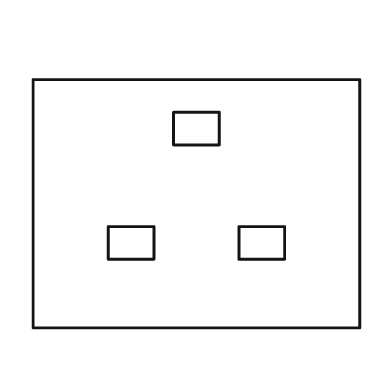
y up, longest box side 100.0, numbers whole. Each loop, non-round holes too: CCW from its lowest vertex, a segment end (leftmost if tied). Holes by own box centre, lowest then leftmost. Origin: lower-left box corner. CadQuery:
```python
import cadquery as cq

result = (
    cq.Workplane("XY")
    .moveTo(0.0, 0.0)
    .lineTo(100.0, 0.0)
    .lineTo(100.0, 76.0)
    .lineTo(0.0, 76.0)
    .close()
    .moveTo(23.0, 21.0)
    .lineTo(37.0, 21.0)
    .lineTo(37.0, 31.0)
    .lineTo(23.0, 31.0)
    .close()
    .moveTo(63.0, 21.0)
    .lineTo(77.0, 21.0)
    .lineTo(77.0, 31.0)
    .lineTo(63.0, 31.0)
    .close()
    .moveTo(43.0, 56.0)
    .lineTo(57.0, 56.0)
    .lineTo(57.0, 66.0)
    .lineTo(43.0, 66.0)
    .close()
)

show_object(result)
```